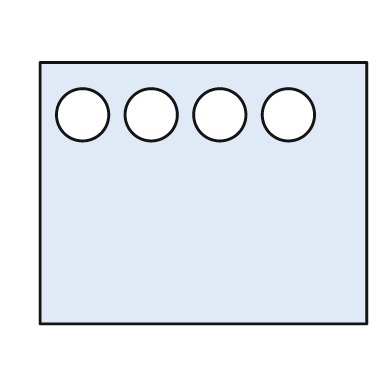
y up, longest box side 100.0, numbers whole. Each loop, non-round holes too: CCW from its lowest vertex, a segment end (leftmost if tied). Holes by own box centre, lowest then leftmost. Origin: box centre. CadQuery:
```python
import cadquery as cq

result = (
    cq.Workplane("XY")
    .moveTo(-50.0, -40.0)
    .lineTo(50.0, -40.0)
    .lineTo(50.0, 40.0)
    .lineTo(-50.0, 40.0)
    .close()
    .moveTo(-37.0, 24.0)
    .circle(8.0)
    .moveTo(-16.0, 24.0)
    .circle(8.0)
    .moveTo(5.0, 24.0)
    .circle(8.0)
    .moveTo(26.0, 24.0)
    .circle(8.0)
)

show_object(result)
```